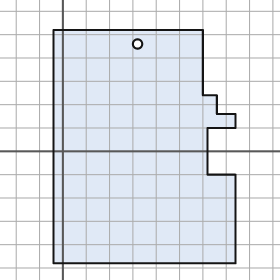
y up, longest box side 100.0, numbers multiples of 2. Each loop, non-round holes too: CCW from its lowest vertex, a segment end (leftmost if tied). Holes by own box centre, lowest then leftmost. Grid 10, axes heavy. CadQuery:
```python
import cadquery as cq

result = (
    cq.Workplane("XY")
    .moveTo(-4.0, -48.0)
    .lineTo(74.0, -48.0)
    .lineTo(74.0, -10.0)
    .lineTo(62.0, -10.0)
    .lineTo(62.0, 10.0)
    .lineTo(74.0, 10.0)
    .lineTo(74.0, 16.0)
    .lineTo(66.0, 16.0)
    .lineTo(66.0, 24.0)
    .lineTo(60.0, 24.0)
    .lineTo(60.0, 52.0)
    .lineTo(-4.0, 52.0)
    .close()
    .moveTo(32.0, 46.0)
    .circle(2.0)
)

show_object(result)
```